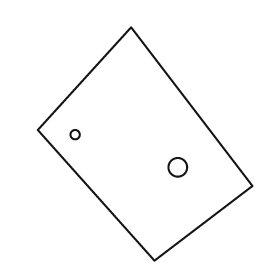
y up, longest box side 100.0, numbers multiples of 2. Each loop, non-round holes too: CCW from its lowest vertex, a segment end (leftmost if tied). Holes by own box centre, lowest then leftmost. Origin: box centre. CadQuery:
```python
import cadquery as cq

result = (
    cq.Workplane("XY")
    .moveTo(4.0, -50.0)
    .lineTo(46.0, -18.0)
    .lineTo(-6.0, 50.0)
    .lineTo(-46.0, 6.0)
    .close()
    .moveTo(14.0, -10.0)
    .circle(4.0)
    .moveTo(-30.0, 4.0)
    .circle(2.0)
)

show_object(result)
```